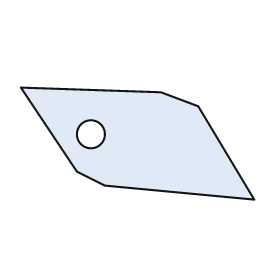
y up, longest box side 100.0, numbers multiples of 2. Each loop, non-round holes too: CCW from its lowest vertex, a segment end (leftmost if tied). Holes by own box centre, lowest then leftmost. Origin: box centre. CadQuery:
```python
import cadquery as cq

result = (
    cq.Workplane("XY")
    .moveTo(50.0, -24.0)
    .lineTo(26.0, 16.0)
    .lineTo(10.0, 22.0)
    .lineTo(-50.0, 24.0)
    .lineTo(-26.0, -12.0)
    .lineTo(-14.0, -18.0)
    .close()
    .moveTo(-20.0, 4.0)
    .circle(6.0)
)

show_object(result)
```